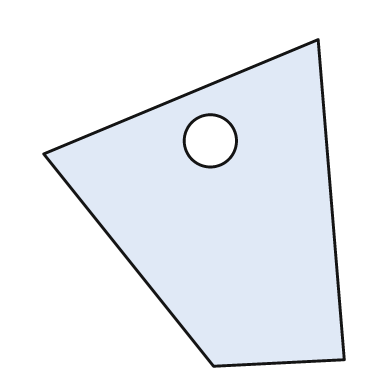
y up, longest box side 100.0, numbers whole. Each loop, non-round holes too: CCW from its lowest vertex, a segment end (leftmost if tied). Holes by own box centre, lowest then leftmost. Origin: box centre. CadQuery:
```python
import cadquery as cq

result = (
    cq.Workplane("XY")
    .moveTo(6.0, -50.0)
    .lineTo(46.0, -48.0)
    .lineTo(38.0, 50.0)
    .lineTo(-46.0, 15.0)
    .close()
    .moveTo(5.0, 19.0)
    .circle(8.0)
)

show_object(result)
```